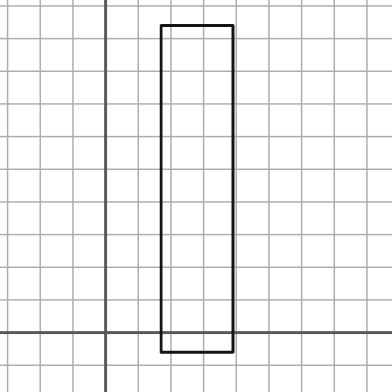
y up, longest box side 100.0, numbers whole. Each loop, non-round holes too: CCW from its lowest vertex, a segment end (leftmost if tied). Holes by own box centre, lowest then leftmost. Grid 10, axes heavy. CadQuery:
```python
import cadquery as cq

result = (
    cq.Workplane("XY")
    .moveTo(17.0, -6.0)
    .lineTo(39.0, -6.0)
    .lineTo(39.0, 94.0)
    .lineTo(17.0, 94.0)
    .close()
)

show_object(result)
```